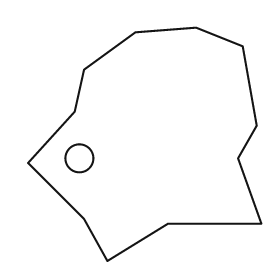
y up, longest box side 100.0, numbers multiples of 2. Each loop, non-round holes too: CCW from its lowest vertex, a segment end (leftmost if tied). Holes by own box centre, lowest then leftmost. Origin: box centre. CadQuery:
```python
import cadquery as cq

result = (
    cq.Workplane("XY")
    .moveTo(-16.0, -50.0)
    .lineTo(10.0, -34.0)
    .lineTo(50.0, -34.0)
    .lineTo(40.0, -6.0)
    .lineTo(48.0, 8.0)
    .lineTo(42.0, 42.0)
    .lineTo(22.0, 50.0)
    .lineTo(-4.0, 48.0)
    .lineTo(-26.0, 32.0)
    .lineTo(-30.0, 14.0)
    .lineTo(-50.0, -8.0)
    .lineTo(-26.0, -32.0)
    .close()
    .moveTo(-28.0, -6.0)
    .circle(6.0)
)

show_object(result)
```